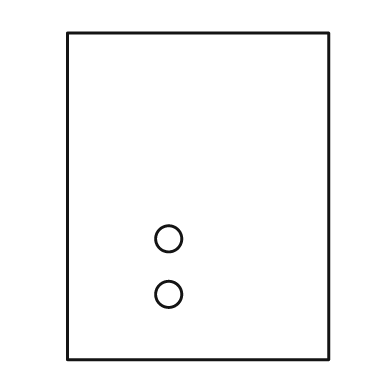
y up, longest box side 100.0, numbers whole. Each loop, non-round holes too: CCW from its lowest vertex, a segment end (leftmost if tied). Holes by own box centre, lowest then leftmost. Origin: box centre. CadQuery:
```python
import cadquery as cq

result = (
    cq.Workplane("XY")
    .moveTo(-40.0, -50.0)
    .lineTo(40.0, -50.0)
    .lineTo(40.0, 50.0)
    .lineTo(-40.0, 50.0)
    .close()
    .moveTo(-9.0, -30.0)
    .circle(4.0)
    .moveTo(-9.0, -13.0)
    .circle(4.0)
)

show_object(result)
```